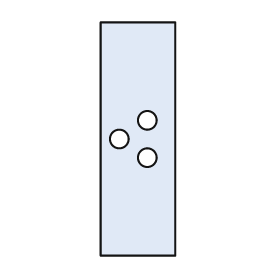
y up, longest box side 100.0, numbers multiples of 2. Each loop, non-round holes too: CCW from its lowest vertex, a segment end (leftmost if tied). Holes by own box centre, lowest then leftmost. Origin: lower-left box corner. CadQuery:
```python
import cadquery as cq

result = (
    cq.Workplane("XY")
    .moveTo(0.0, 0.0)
    .lineTo(32.0, 0.0)
    .lineTo(32.0, 100.0)
    .lineTo(0.0, 100.0)
    .close()
    .moveTo(20.0, 42.0)
    .circle(4.0)
    .moveTo(8.0, 50.0)
    .circle(4.0)
    .moveTo(20.0, 58.0)
    .circle(4.0)
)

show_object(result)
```